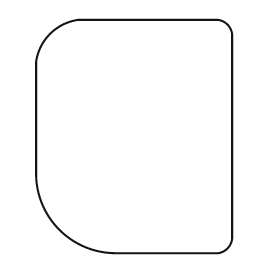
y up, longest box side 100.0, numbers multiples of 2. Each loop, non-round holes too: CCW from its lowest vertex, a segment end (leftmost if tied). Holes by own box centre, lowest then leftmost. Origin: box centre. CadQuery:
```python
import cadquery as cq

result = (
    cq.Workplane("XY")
    .moveTo(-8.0, -50.0)
    .lineTo(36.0, -50.0)
    .threePointArc((40.0, -48.0), (42.0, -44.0))
    .lineTo(42.0, 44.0)
    .threePointArc((40.0, 48.0), (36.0, 50.0))
    .lineTo(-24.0, 50.0)
    .threePointArc((-36.0, 44.0), (-42.0, 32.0))
    .lineTo(-42.0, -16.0)
    .threePointArc((-32.0, -40.0), (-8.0, -50.0))
    .close()
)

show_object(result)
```